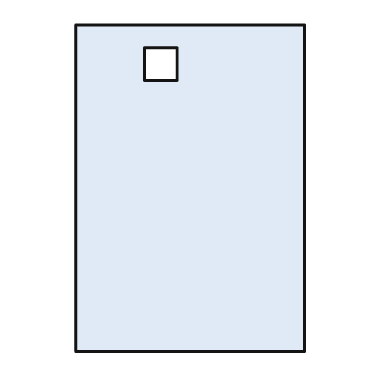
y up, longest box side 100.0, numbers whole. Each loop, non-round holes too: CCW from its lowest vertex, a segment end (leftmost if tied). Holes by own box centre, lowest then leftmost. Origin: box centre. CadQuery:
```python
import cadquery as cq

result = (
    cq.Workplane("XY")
    .moveTo(-35.0, -50.0)
    .lineTo(35.0, -50.0)
    .lineTo(35.0, 50.0)
    .lineTo(-35.0, 50.0)
    .close()
    .moveTo(-14.0, 33.0)
    .lineTo(-4.0, 33.0)
    .lineTo(-4.0, 43.0)
    .lineTo(-14.0, 43.0)
    .close()
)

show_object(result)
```